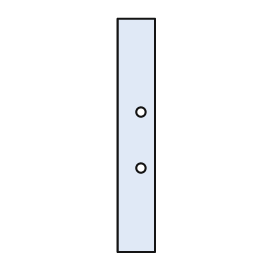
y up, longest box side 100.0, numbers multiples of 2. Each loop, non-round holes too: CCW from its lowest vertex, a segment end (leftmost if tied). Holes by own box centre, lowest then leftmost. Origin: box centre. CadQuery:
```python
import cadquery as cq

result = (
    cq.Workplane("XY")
    .moveTo(-8.0, -50.0)
    .lineTo(8.0, -50.0)
    .lineTo(8.0, 50.0)
    .lineTo(-8.0, 50.0)
    .close()
    .moveTo(2.0, -14.0)
    .circle(2.0)
    .moveTo(2.0, 10.0)
    .circle(2.0)
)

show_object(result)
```